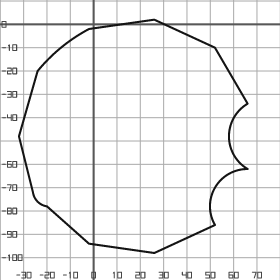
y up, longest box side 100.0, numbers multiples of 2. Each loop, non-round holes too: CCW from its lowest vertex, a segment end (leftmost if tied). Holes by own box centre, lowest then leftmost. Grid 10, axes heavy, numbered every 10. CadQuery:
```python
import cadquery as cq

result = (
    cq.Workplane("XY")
    .moveTo(26.0, -98.0)
    .lineTo(52.0, -86.0)
    .threePointArc((52.0, -70.0), (66.0, -62.0))
    .threePointArc((58.0, -48.0), (66.0, -34.0))
    .lineTo(52.0, -10.0)
    .lineTo(26.0, 2.0)
    .lineTo(-2.0, -2.0)
    .threePointArc((-14.0, -10.0), (-24.0, -20.0))
    .lineTo(-32.0, -48.0)
    .lineTo(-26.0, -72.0)
    .threePointArc((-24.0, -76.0), (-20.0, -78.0))
    .lineTo(-2.0, -94.0)
    .close()
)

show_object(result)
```